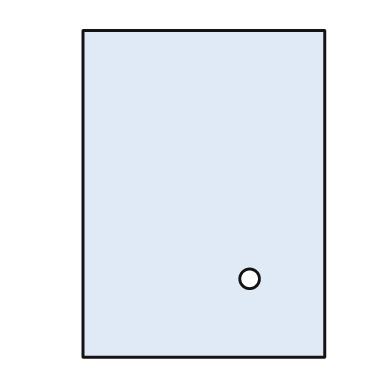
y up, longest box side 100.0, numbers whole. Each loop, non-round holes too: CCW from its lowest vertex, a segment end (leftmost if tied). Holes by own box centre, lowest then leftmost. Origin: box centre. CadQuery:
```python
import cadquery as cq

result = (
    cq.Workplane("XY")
    .moveTo(-37.0, -50.0)
    .lineTo(37.0, -50.0)
    .lineTo(37.0, 50.0)
    .lineTo(-37.0, 50.0)
    .close()
    .moveTo(14.0, -26.0)
    .circle(3.0)
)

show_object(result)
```